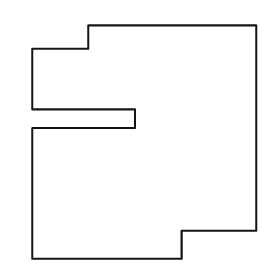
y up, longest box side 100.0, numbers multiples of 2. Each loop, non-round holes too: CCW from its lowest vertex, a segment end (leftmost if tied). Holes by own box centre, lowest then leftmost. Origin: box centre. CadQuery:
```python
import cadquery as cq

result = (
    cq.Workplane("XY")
    .moveTo(-48.0, -50.0)
    .lineTo(16.0, -50.0)
    .lineTo(16.0, -38.0)
    .lineTo(48.0, -38.0)
    .lineTo(48.0, 50.0)
    .lineTo(-24.0, 50.0)
    .lineTo(-24.0, 40.0)
    .lineTo(-48.0, 40.0)
    .lineTo(-48.0, 14.0)
    .lineTo(-4.0, 14.0)
    .lineTo(-4.0, 6.0)
    .lineTo(-48.0, 6.0)
    .close()
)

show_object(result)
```